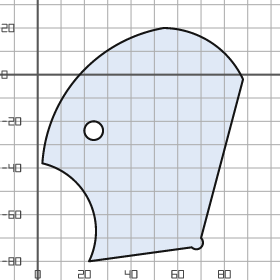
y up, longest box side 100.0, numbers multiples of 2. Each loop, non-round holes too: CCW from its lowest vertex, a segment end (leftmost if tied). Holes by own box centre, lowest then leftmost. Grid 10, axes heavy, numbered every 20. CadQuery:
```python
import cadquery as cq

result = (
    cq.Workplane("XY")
    .moveTo(22.0, -80.0)
    .lineTo(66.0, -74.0)
    .threePointArc((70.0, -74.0), (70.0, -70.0))
    .lineTo(88.0, -2.0)
    .threePointArc((74.0, 14.0), (54.0, 20.0))
    .threePointArc((18.0, 0.0), (2.0, -38.0))
    .threePointArc((22.0, -54.0), (22.0, -80.0))
    .close()
    .moveTo(24.0, -24.0)
    .circle(4.0)
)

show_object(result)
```